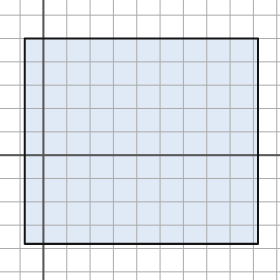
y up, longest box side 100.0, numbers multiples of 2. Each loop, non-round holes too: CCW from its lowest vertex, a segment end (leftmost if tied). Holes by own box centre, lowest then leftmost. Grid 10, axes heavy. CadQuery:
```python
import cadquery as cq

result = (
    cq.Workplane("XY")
    .moveTo(-8.0, -38.0)
    .lineTo(92.0, -38.0)
    .lineTo(92.0, 50.0)
    .lineTo(-8.0, 50.0)
    .close()
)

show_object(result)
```